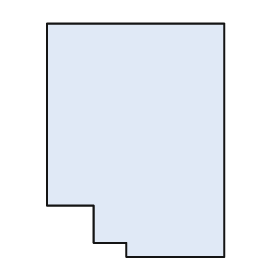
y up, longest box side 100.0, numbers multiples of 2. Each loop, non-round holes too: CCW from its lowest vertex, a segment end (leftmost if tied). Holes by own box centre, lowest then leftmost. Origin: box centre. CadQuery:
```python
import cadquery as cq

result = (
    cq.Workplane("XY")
    .moveTo(-4.0, -50.0)
    .lineTo(38.0, -50.0)
    .lineTo(38.0, 50.0)
    .lineTo(-38.0, 50.0)
    .lineTo(-38.0, -28.0)
    .lineTo(-18.0, -28.0)
    .lineTo(-18.0, -44.0)
    .lineTo(-4.0, -44.0)
    .close()
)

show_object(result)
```